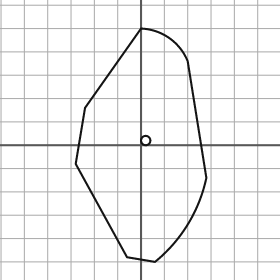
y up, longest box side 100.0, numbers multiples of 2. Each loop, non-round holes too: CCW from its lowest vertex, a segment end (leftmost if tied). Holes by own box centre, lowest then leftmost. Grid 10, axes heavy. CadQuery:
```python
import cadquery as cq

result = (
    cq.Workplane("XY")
    .moveTo(6.0, -50.0)
    .threePointArc((20.0, -34.0), (28.0, -14.0))
    .lineTo(20.0, 36.0)
    .threePointArc((12.0, 46.0), (0.0, 50.0))
    .lineTo(-24.0, 16.0)
    .lineTo(-28.0, -8.0)
    .lineTo(-6.0, -48.0)
    .close()
    .moveTo(2.0, 2.0)
    .circle(2.0)
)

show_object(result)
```